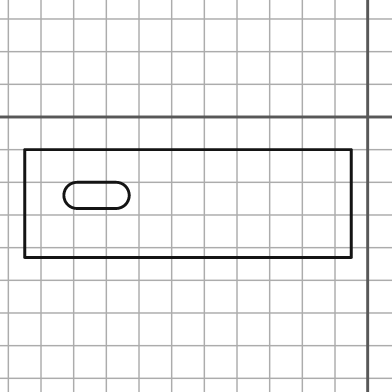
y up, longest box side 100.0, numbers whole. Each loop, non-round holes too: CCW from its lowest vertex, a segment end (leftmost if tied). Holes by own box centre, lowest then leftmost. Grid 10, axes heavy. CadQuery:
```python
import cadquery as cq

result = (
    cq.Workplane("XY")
    .moveTo(-105.0, -43.0)
    .lineTo(-5.0, -43.0)
    .lineTo(-5.0, -10.0)
    .lineTo(-105.0, -10.0)
    .close()
    .moveTo(-89.0, -28.0)
    .lineTo(-77.0, -28.0)
    .threePointArc((-73.0, -24.0), (-77.0, -20.0))
    .lineTo(-89.0, -20.0)
    .threePointArc((-93.0, -24.0), (-89.0, -28.0))
    .close()
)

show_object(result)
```